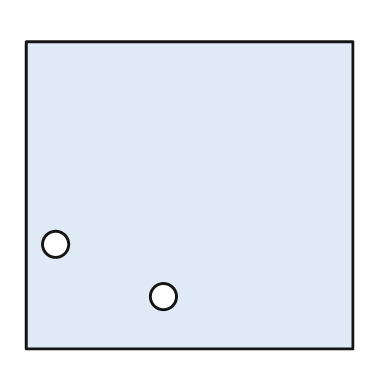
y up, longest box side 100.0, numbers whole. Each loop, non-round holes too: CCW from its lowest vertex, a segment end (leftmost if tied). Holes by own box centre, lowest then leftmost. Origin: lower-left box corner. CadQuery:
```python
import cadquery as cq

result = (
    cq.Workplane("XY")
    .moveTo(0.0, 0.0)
    .lineTo(100.0, 0.0)
    .lineTo(100.0, 94.0)
    .lineTo(0.0, 94.0)
    .close()
    .moveTo(42.0, 16.0)
    .circle(4.0)
    .moveTo(9.0, 32.0)
    .circle(4.0)
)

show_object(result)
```